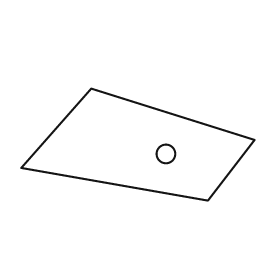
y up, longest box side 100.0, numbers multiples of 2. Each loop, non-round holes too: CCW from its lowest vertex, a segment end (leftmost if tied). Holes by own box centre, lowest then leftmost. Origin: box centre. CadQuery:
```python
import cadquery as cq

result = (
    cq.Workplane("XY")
    .moveTo(30.0, -24.0)
    .lineTo(50.0, 2.0)
    .lineTo(-20.0, 24.0)
    .lineTo(-50.0, -10.0)
    .close()
    .moveTo(12.0, -4.0)
    .circle(4.0)
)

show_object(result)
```